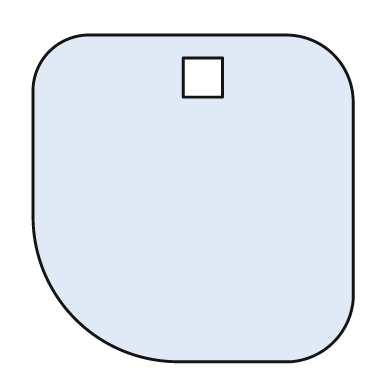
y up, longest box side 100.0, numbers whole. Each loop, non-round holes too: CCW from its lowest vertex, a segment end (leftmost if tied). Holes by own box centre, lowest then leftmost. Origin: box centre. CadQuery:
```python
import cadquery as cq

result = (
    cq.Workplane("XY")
    .moveTo(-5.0, -50.0)
    .lineTo(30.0, -50.0)
    .threePointArc((43.0, -44.0), (49.0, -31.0))
    .lineTo(49.0, 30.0)
    .threePointArc((43.0, 44.0), (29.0, 50.0))
    .lineTo(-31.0, 50.0)
    .threePointArc((-44.0, 45.0), (-49.0, 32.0))
    .lineTo(-49.0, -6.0)
    .threePointArc((-36.0, -37.0), (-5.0, -50.0))
    .close()
    .moveTo(-3.0, 31.0)
    .lineTo(9.0, 31.0)
    .lineTo(9.0, 43.0)
    .lineTo(-3.0, 43.0)
    .close()
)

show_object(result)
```